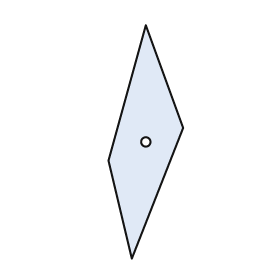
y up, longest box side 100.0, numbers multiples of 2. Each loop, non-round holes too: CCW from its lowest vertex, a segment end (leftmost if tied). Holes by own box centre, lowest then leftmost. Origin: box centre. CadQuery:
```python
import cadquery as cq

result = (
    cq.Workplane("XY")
    .moveTo(-6.0, -50.0)
    .lineTo(16.0, 6.0)
    .lineTo(0.0, 50.0)
    .lineTo(-16.0, -8.0)
    .close()
    .moveTo(0.0, 0.0)
    .circle(2.0)
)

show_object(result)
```